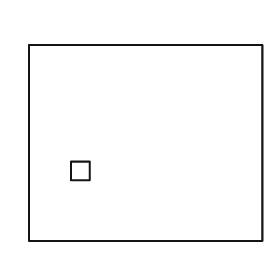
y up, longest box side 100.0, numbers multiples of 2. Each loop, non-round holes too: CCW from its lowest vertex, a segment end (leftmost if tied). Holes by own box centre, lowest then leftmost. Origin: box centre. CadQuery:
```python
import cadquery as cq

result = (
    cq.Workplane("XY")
    .moveTo(-50.0, -42.0)
    .lineTo(50.0, -42.0)
    .lineTo(50.0, 42.0)
    .lineTo(-50.0, 42.0)
    .close()
    .moveTo(-32.0, -16.0)
    .lineTo(-24.0, -16.0)
    .lineTo(-24.0, -8.0)
    .lineTo(-32.0, -8.0)
    .close()
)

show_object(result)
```